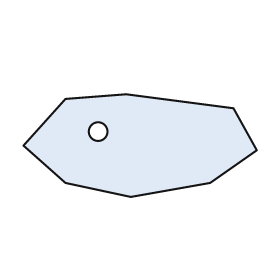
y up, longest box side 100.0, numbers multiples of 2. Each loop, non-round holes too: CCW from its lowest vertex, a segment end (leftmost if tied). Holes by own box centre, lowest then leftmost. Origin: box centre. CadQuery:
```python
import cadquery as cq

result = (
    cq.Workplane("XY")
    .moveTo(-4.0, -22.0)
    .lineTo(30.0, -16.0)
    .lineTo(50.0, -2.0)
    .lineTo(40.0, 16.0)
    .lineTo(-6.0, 22.0)
    .lineTo(-32.0, 20.0)
    .lineTo(-50.0, 0.0)
    .lineTo(-32.0, -16.0)
    .close()
    .moveTo(-18.0, 6.0)
    .circle(4.0)
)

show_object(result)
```